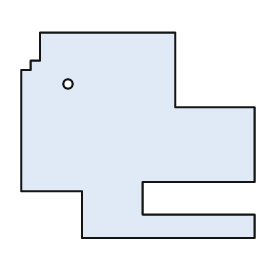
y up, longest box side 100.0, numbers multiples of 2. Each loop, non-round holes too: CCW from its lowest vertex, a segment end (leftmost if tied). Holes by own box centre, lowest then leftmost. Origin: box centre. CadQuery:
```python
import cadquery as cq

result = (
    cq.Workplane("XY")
    .moveTo(-24.0, -44.0)
    .lineTo(50.0, -44.0)
    .lineTo(50.0, -34.0)
    .lineTo(2.0, -34.0)
    .lineTo(2.0, -20.0)
    .lineTo(50.0, -20.0)
    .lineTo(50.0, 12.0)
    .lineTo(16.0, 12.0)
    .lineTo(16.0, 44.0)
    .lineTo(-42.0, 44.0)
    .lineTo(-42.0, 32.0)
    .lineTo(-46.0, 32.0)
    .lineTo(-46.0, 28.0)
    .lineTo(-50.0, 28.0)
    .lineTo(-50.0, -24.0)
    .lineTo(-24.0, -24.0)
    .close()
    .moveTo(-30.0, 22.0)
    .circle(2.0)
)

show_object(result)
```